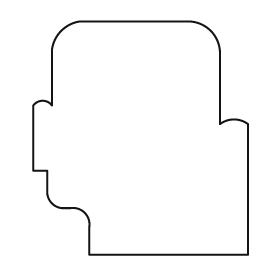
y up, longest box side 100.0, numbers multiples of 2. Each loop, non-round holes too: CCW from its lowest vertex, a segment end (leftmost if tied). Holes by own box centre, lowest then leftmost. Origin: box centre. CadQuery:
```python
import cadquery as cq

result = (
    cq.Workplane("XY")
    .moveTo(-22.0, -50.0)
    .lineTo(46.0, -50.0)
    .lineTo(46.0, 6.0)
    .threePointArc((40.0, 8.0), (34.0, 6.0))
    .lineTo(34.0, 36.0)
    .threePointArc((30.0, 46.0), (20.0, 50.0))
    .lineTo(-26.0, 50.0)
    .threePointArc((-34.0, 46.0), (-38.0, 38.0))
    .lineTo(-38.0, 14.0)
    .threePointArc((-42.0, 16.0), (-46.0, 14.0))
    .lineTo(-46.0, -14.0)
    .lineTo(-40.0, -14.0)
    .lineTo(-40.0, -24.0)
    .threePointArc((-38.0, -28.0), (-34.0, -30.0))
    .lineTo(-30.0, -30.0)
    .threePointArc((-24.0, -32.0), (-22.0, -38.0))
    .close()
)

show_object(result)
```